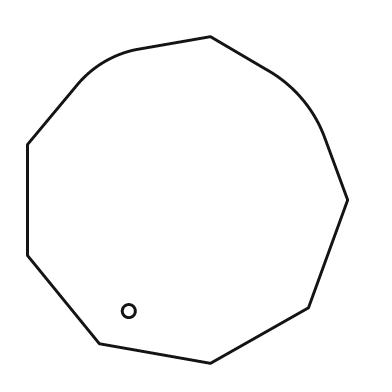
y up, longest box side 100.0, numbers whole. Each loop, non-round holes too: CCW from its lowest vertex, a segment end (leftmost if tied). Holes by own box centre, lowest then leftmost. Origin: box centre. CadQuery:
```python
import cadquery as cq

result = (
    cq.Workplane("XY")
    .moveTo(7.0, -50.0)
    .lineTo(37.0, -33.0)
    .lineTo(49.0, 0.0)
    .lineTo(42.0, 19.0)
    .threePointArc((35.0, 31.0), (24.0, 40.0))
    .lineTo(7.0, 50.0)
    .lineTo(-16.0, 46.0)
    .threePointArc((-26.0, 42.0), (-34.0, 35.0))
    .lineTo(-49.0, 17.0)
    .lineTo(-49.0, -17.0)
    .lineTo(-27.0, -44.0)
    .close()
    .moveTo(-18.0, -34.0)
    .circle(2.0)
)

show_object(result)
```